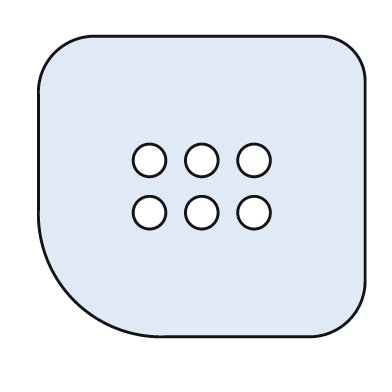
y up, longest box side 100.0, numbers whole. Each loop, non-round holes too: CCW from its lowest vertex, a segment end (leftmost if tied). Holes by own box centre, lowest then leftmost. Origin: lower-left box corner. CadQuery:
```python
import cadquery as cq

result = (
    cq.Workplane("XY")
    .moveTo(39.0, 0.0)
    .lineTo(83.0, 0.0)
    .threePointArc((95.0, 5.0), (100.0, 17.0))
    .lineTo(100.0, 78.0)
    .threePointArc((96.0, 88.0), (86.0, 92.0))
    .lineTo(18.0, 92.0)
    .threePointArc((5.0, 87.0), (0.0, 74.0))
    .lineTo(0.0, 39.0)
    .threePointArc((11.0, 11.0), (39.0, 0.0))
    .close()
    .moveTo(34.0, 38.0)
    .circle(5.0)
    .moveTo(50.0, 38.0)
    .circle(5.0)
    .moveTo(66.0, 38.0)
    .circle(5.0)
    .moveTo(34.0, 54.0)
    .circle(5.0)
    .moveTo(50.0, 54.0)
    .circle(5.0)
    .moveTo(66.0, 54.0)
    .circle(5.0)
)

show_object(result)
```